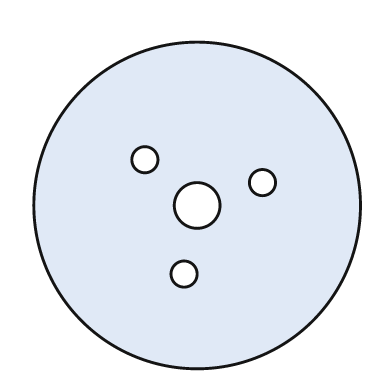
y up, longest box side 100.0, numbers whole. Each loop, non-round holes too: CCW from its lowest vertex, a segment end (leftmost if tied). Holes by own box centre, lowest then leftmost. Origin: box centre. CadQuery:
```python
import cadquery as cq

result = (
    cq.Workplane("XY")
    .moveTo(0.0, 0.0)
    .circle(50.0)
    .moveTo(-4.0, -21.0)
    .circle(4.0)
    .moveTo(0.0, 0.0)
    .circle(7.0)
    .moveTo(20.0, 7.0)
    .circle(4.0)
    .moveTo(-16.0, 14.0)
    .circle(4.0)
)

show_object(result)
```